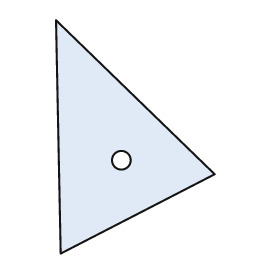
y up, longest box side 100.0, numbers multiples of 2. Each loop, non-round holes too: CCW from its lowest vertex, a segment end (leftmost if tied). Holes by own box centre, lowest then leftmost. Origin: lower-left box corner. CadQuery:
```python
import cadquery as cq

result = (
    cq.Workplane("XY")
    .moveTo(2.0, 0.0)
    .lineTo(68.0, 34.0)
    .lineTo(0.0, 100.0)
    .close()
    .moveTo(28.0, 40.0)
    .circle(4.0)
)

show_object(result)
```